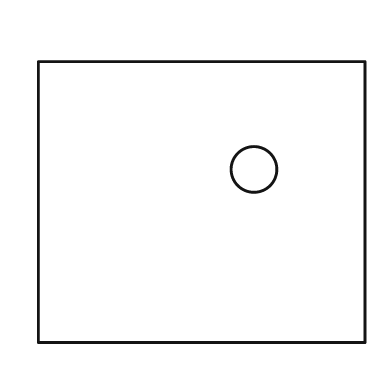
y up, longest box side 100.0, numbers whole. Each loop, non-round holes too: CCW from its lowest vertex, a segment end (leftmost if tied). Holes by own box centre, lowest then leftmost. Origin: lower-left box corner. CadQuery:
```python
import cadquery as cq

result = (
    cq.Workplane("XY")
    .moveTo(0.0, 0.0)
    .lineTo(100.0, 0.0)
    .lineTo(100.0, 86.0)
    .lineTo(0.0, 86.0)
    .close()
    .moveTo(66.0, 53.0)
    .circle(7.0)
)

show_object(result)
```